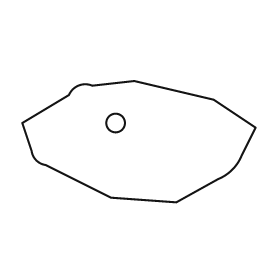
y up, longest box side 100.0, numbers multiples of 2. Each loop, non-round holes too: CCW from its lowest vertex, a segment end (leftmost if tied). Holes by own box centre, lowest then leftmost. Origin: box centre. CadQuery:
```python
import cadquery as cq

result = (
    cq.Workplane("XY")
    .moveTo(16.0, -26.0)
    .lineTo(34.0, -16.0)
    .threePointArc((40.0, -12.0), (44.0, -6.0))
    .lineTo(50.0, 6.0)
    .lineTo(32.0, 18.0)
    .lineTo(-2.0, 26.0)
    .lineTo(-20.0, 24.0)
    .threePointArc((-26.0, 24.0), (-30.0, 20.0))
    .lineTo(-50.0, 8.0)
    .lineTo(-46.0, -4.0)
    .threePointArc((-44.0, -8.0), (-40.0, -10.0))
    .lineTo(-12.0, -24.0)
    .close()
    .moveTo(-10.0, 8.0)
    .circle(4.0)
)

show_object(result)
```